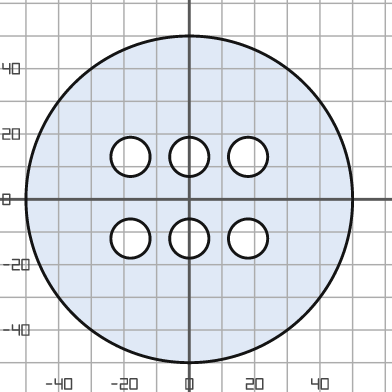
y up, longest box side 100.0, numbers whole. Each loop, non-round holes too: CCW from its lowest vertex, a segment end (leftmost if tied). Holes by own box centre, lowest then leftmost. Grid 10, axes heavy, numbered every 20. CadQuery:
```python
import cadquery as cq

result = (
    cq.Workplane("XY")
    .moveTo(0.0, 0.0)
    .circle(50.0)
    .moveTo(-18.0, -12.0)
    .circle(6.0)
    .moveTo(0.0, -12.0)
    .circle(6.0)
    .moveTo(18.0, -12.0)
    .circle(6.0)
    .moveTo(-18.0, 13.0)
    .circle(6.0)
    .moveTo(0.0, 13.0)
    .circle(6.0)
    .moveTo(18.0, 13.0)
    .circle(6.0)
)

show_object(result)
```